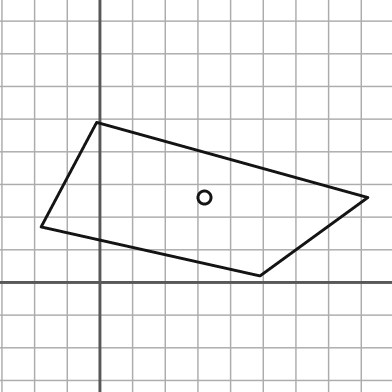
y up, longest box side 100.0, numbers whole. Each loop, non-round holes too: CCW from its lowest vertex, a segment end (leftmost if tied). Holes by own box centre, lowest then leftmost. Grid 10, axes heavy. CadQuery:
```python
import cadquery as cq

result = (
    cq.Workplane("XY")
    .moveTo(49.0, 2.0)
    .lineTo(82.0, 26.0)
    .lineTo(-1.0, 49.0)
    .lineTo(-18.0, 17.0)
    .close()
    .moveTo(32.0, 26.0)
    .circle(2.0)
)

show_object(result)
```